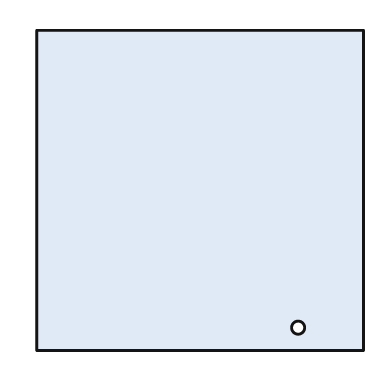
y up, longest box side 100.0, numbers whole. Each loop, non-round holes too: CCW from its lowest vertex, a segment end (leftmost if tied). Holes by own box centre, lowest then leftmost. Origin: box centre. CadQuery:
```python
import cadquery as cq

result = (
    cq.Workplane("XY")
    .moveTo(-50.0, -49.0)
    .lineTo(50.0, -49.0)
    .lineTo(50.0, 49.0)
    .lineTo(-50.0, 49.0)
    .close()
    .moveTo(30.0, -42.0)
    .circle(2.0)
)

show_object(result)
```